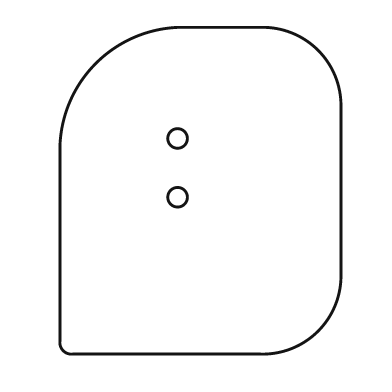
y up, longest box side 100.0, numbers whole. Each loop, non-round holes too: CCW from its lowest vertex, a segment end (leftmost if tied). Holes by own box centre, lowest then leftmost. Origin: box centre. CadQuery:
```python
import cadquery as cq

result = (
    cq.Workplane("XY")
    .moveTo(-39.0, -50.0)
    .lineTo(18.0, -50.0)
    .threePointArc((36.0, -43.0), (43.0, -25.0))
    .lineTo(43.0, 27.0)
    .threePointArc((36.0, 43.0), (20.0, 50.0))
    .lineTo(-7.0, 50.0)
    .threePointArc((-32.0, 39.0), (-43.0, 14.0))
    .lineTo(-43.0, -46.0)
    .threePointArc((-42.0, -49.0), (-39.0, -50.0))
    .close()
    .moveTo(-7.0, -2.0)
    .circle(3.0)
    .moveTo(-7.0, 16.0)
    .circle(3.0)
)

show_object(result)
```